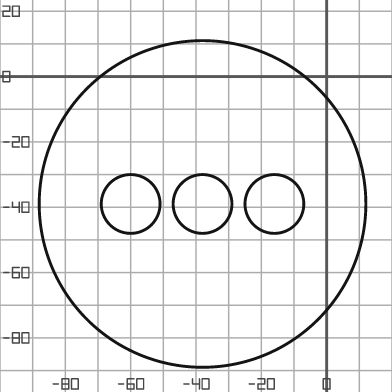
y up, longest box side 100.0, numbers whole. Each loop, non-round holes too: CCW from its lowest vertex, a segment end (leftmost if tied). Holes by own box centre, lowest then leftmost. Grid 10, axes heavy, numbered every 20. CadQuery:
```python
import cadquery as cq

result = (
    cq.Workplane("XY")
    .moveTo(-38.0, -39.0)
    .circle(50.0)
    .moveTo(-60.0, -39.0)
    .circle(9.0)
    .moveTo(-38.0, -39.0)
    .circle(9.0)
    .moveTo(-16.0, -39.0)
    .circle(9.0)
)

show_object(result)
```